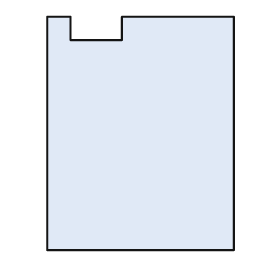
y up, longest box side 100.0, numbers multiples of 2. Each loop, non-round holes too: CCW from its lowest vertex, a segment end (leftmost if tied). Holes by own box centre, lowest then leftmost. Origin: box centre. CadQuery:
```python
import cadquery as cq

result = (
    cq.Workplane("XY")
    .moveTo(-40.0, -50.0)
    .lineTo(40.0, -50.0)
    .lineTo(40.0, 50.0)
    .lineTo(-8.0, 50.0)
    .lineTo(-8.0, 40.0)
    .lineTo(-30.0, 40.0)
    .lineTo(-30.0, 50.0)
    .lineTo(-40.0, 50.0)
    .close()
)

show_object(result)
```